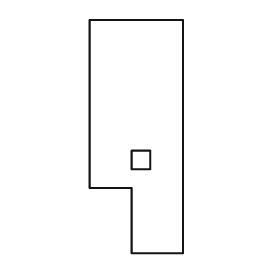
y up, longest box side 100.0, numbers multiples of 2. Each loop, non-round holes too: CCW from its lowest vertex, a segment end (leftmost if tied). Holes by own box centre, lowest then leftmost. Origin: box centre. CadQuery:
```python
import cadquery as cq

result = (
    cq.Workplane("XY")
    .moveTo(-2.0, -50.0)
    .lineTo(20.0, -50.0)
    .lineTo(20.0, 50.0)
    .lineTo(-20.0, 50.0)
    .lineTo(-20.0, -22.0)
    .lineTo(-2.0, -22.0)
    .close()
    .moveTo(-2.0, -14.0)
    .lineTo(6.0, -14.0)
    .lineTo(6.0, -6.0)
    .lineTo(-2.0, -6.0)
    .close()
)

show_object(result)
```